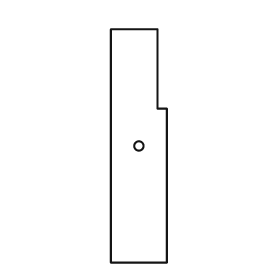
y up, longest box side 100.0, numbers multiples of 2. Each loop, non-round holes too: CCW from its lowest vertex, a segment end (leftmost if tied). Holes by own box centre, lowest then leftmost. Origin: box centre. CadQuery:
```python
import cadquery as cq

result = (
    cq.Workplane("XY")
    .moveTo(-12.0, -50.0)
    .lineTo(12.0, -50.0)
    .lineTo(12.0, 16.0)
    .lineTo(8.0, 16.0)
    .lineTo(8.0, 50.0)
    .lineTo(-12.0, 50.0)
    .close()
    .moveTo(0.0, 0.0)
    .circle(2.0)
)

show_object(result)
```